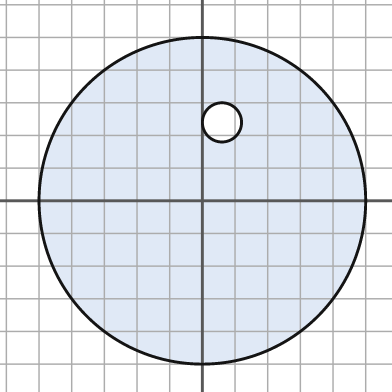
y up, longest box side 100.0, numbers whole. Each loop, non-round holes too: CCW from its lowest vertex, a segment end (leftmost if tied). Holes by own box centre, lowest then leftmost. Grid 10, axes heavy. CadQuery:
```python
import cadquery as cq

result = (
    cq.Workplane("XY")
    .moveTo(0.0, 0.0)
    .circle(50.0)
    .moveTo(6.0, 24.0)
    .circle(6.0)
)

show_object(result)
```